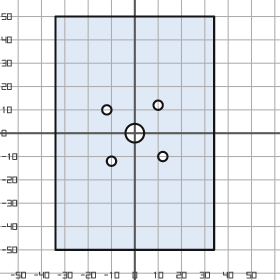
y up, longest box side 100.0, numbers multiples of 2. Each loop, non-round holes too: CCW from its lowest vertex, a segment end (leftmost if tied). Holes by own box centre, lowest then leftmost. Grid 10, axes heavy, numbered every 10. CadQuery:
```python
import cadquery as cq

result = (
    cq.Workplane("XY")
    .moveTo(-34.0, -50.0)
    .lineTo(34.0, -50.0)
    .lineTo(34.0, 50.0)
    .lineTo(-34.0, 50.0)
    .close()
    .moveTo(-10.0, -12.0)
    .circle(2.0)
    .moveTo(12.0, -10.0)
    .circle(2.0)
    .moveTo(0.0, 0.0)
    .circle(4.0)
    .moveTo(-12.0, 10.0)
    .circle(2.0)
    .moveTo(10.0, 12.0)
    .circle(2.0)
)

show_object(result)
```